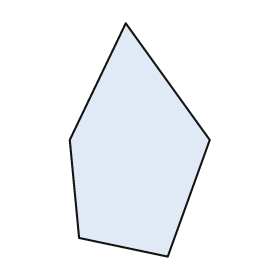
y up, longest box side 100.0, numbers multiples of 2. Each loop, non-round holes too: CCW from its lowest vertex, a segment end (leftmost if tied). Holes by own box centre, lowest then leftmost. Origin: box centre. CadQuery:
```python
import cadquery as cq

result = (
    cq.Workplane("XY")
    .moveTo(12.0, -50.0)
    .lineTo(30.0, 0.0)
    .lineTo(-6.0, 50.0)
    .lineTo(-30.0, 0.0)
    .lineTo(-26.0, -42.0)
    .close()
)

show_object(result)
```